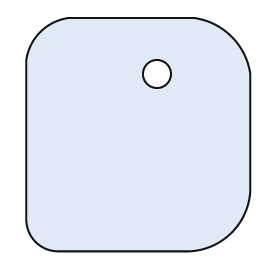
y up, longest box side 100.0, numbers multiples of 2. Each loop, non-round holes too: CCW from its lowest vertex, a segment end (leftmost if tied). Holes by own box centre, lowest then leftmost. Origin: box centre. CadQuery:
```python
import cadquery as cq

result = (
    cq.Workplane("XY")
    .moveTo(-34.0, -50.0)
    .lineTo(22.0, -50.0)
    .threePointArc((40.0, -42.0), (48.0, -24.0))
    .lineTo(48.0, 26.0)
    .threePointArc((40.0, 42.0), (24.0, 50.0))
    .lineTo(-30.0, 50.0)
    .threePointArc((-42.0, 44.0), (-48.0, 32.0))
    .lineTo(-48.0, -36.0)
    .threePointArc((-44.0, -46.0), (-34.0, -50.0))
    .close()
    .moveTo(8.0, 26.0)
    .circle(6.0)
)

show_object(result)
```